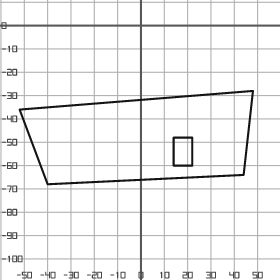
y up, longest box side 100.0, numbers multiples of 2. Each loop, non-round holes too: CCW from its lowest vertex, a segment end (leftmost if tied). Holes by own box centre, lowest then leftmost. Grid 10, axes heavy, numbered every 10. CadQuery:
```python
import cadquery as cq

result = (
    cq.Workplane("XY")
    .moveTo(-40.0, -68.0)
    .lineTo(44.0, -64.0)
    .lineTo(48.0, -28.0)
    .lineTo(-52.0, -36.0)
    .close()
    .moveTo(14.0, -60.0)
    .lineTo(22.0, -60.0)
    .lineTo(22.0, -48.0)
    .lineTo(14.0, -48.0)
    .close()
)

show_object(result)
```